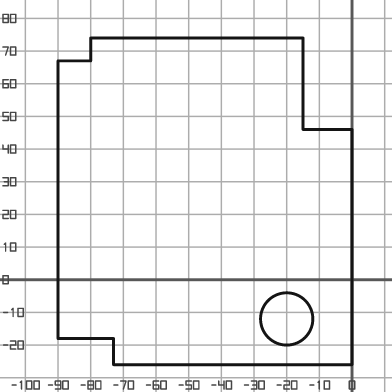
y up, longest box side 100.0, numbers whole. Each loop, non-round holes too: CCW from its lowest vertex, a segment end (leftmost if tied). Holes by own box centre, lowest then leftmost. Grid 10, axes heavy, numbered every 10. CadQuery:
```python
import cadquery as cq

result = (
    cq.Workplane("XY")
    .moveTo(-73.0, -26.0)
    .lineTo(0.0, -26.0)
    .lineTo(0.0, 46.0)
    .lineTo(-15.0, 46.0)
    .lineTo(-15.0, 74.0)
    .lineTo(-80.0, 74.0)
    .lineTo(-80.0, 67.0)
    .lineTo(-90.0, 67.0)
    .lineTo(-90.0, -18.0)
    .lineTo(-73.0, -18.0)
    .close()
    .moveTo(-20.0, -12.0)
    .circle(8.0)
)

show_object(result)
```